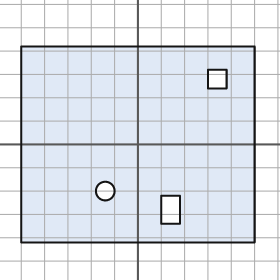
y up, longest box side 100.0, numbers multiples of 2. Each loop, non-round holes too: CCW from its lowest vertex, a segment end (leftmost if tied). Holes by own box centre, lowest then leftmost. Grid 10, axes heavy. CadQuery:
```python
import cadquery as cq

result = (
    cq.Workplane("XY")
    .moveTo(-50.0, -42.0)
    .lineTo(50.0, -42.0)
    .lineTo(50.0, 42.0)
    .lineTo(-50.0, 42.0)
    .close()
    .moveTo(10.0, -34.0)
    .lineTo(18.0, -34.0)
    .lineTo(18.0, -22.0)
    .lineTo(10.0, -22.0)
    .close()
    .moveTo(-14.0, -20.0)
    .circle(4.0)
    .moveTo(30.0, 24.0)
    .lineTo(38.0, 24.0)
    .lineTo(38.0, 32.0)
    .lineTo(30.0, 32.0)
    .close()
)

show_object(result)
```